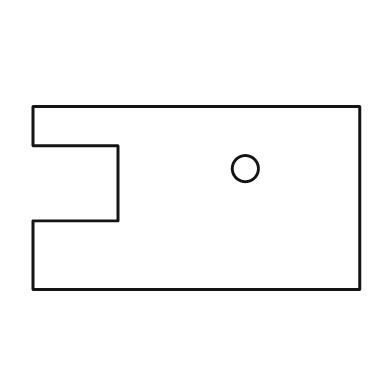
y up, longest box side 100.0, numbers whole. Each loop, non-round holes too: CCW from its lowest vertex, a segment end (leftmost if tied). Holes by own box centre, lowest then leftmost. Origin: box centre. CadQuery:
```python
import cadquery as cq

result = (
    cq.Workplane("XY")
    .moveTo(-50.0, -28.0)
    .lineTo(50.0, -28.0)
    .lineTo(50.0, 28.0)
    .lineTo(-50.0, 28.0)
    .lineTo(-50.0, 16.0)
    .lineTo(-24.0, 16.0)
    .lineTo(-24.0, -7.0)
    .lineTo(-50.0, -7.0)
    .close()
    .moveTo(15.0, 9.0)
    .circle(4.0)
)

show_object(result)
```